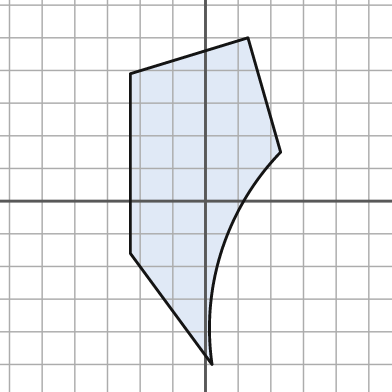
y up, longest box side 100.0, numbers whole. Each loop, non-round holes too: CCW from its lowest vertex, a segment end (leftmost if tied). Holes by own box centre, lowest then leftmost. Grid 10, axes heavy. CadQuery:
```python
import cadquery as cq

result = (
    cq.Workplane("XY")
    .moveTo(2.0, -50.0)
    .threePointArc((5.0, -15.0), (23.0, 15.0))
    .lineTo(13.0, 50.0)
    .lineTo(-23.0, 39.0)
    .lineTo(-23.0, -16.0)
    .close()
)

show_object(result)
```